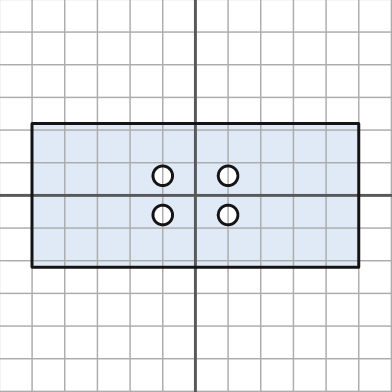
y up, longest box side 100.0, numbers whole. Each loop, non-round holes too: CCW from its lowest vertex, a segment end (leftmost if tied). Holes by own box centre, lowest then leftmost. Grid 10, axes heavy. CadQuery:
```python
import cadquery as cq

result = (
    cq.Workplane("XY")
    .moveTo(-50.0, -22.0)
    .lineTo(50.0, -22.0)
    .lineTo(50.0, 22.0)
    .lineTo(-50.0, 22.0)
    .close()
    .moveTo(-10.0, -6.0)
    .circle(3.0)
    .moveTo(10.0, -6.0)
    .circle(3.0)
    .moveTo(-10.0, 6.0)
    .circle(3.0)
    .moveTo(10.0, 6.0)
    .circle(3.0)
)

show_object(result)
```